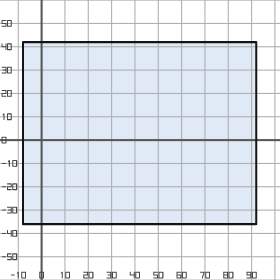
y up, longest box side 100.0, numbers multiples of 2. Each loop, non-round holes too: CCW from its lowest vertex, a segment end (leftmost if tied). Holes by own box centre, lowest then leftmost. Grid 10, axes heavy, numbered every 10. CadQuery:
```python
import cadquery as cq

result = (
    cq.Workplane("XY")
    .moveTo(-8.0, -36.0)
    .lineTo(92.0, -36.0)
    .lineTo(92.0, 42.0)
    .lineTo(-8.0, 42.0)
    .close()
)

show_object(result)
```